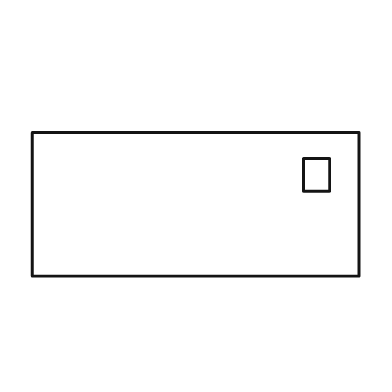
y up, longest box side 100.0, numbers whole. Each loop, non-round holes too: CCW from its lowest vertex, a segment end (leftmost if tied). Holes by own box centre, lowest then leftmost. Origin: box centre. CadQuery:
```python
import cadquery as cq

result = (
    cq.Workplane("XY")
    .moveTo(-50.0, -22.0)
    .lineTo(50.0, -22.0)
    .lineTo(50.0, 22.0)
    .lineTo(-50.0, 22.0)
    .close()
    .moveTo(33.0, 4.0)
    .lineTo(41.0, 4.0)
    .lineTo(41.0, 14.0)
    .lineTo(33.0, 14.0)
    .close()
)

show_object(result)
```